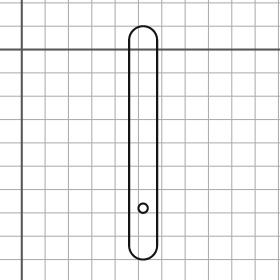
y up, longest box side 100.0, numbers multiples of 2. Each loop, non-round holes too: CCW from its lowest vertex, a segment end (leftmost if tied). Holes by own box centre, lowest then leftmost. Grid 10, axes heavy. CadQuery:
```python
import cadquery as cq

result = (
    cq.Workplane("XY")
    .moveTo(46.0, -84.0)
    .threePointArc((52.0, -90.0), (58.0, -84.0))
    .lineTo(58.0, 4.0)
    .threePointArc((52.0, 10.0), (46.0, 4.0))
    .close()
    .moveTo(52.0, -68.0)
    .circle(2.0)
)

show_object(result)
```